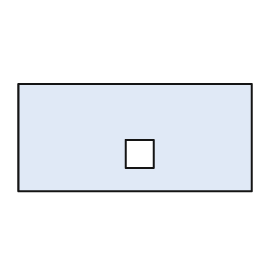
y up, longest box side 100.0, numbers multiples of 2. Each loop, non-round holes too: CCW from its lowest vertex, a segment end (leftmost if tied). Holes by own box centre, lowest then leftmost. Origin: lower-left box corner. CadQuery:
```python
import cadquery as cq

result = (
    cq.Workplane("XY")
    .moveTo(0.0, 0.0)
    .lineTo(100.0, 0.0)
    .lineTo(100.0, 46.0)
    .lineTo(0.0, 46.0)
    .close()
    .moveTo(46.0, 10.0)
    .lineTo(58.0, 10.0)
    .lineTo(58.0, 22.0)
    .lineTo(46.0, 22.0)
    .close()
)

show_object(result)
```